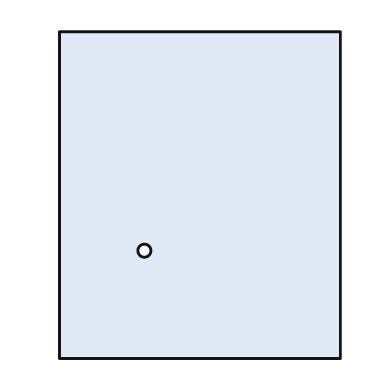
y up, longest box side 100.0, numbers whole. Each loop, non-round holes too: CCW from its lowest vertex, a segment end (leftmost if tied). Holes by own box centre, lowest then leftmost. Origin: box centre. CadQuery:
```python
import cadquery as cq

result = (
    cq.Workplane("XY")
    .moveTo(-43.0, -50.0)
    .lineTo(43.0, -50.0)
    .lineTo(43.0, 50.0)
    .lineTo(-43.0, 50.0)
    .close()
    .moveTo(-17.0, -17.0)
    .circle(2.0)
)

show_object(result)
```